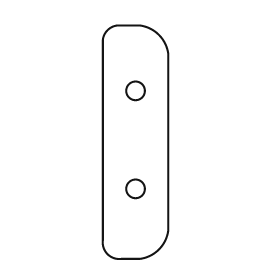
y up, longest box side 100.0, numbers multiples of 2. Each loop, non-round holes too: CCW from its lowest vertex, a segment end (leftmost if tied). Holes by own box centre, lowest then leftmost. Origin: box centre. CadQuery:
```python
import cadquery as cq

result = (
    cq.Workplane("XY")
    .moveTo(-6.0, -50.0)
    .lineTo(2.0, -50.0)
    .threePointArc((10.0, -46.0), (14.0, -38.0))
    .lineTo(14.0, 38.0)
    .threePointArc((10.0, 46.0), (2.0, 50.0))
    .lineTo(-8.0, 50.0)
    .threePointArc((-12.0, 48.0), (-14.0, 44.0))
    .lineTo(-14.0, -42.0)
    .threePointArc((-12.0, -48.0), (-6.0, -50.0))
    .close()
    .moveTo(0.0, -20.0)
    .circle(4.0)
    .moveTo(0.0, 22.0)
    .circle(4.0)
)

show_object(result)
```